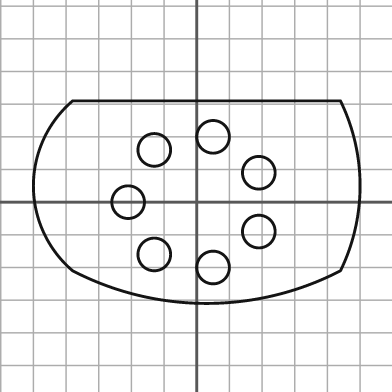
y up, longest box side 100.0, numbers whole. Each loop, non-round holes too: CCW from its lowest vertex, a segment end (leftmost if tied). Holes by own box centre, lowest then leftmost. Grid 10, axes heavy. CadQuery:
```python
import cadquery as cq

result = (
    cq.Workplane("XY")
    .moveTo(-38.0, -21.0)
    .threePointArc((3.0, -31.0), (44.0, -21.0))
    .threePointArc((50.0, 5.0), (44.0, 31.0))
    .lineTo(-38.0, 31.0)
    .threePointArc((-50.0, 5.0), (-38.0, -21.0))
    .close()
    .moveTo(5.0, -20.0)
    .circle(5.0)
    .moveTo(-13.0, -16.0)
    .circle(5.0)
    .moveTo(19.0, -9.0)
    .circle(5.0)
    .moveTo(-21.0, 0.0)
    .circle(5.0)
    .moveTo(19.0, 9.0)
    .circle(5.0)
    .moveTo(-13.0, 16.0)
    .circle(5.0)
    .moveTo(5.0, 20.0)
    .circle(5.0)
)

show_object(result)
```